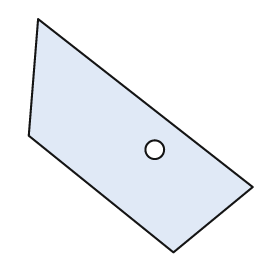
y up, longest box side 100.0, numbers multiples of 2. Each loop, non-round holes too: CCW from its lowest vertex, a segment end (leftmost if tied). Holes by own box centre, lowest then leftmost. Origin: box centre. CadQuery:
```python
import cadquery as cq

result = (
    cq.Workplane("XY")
    .moveTo(14.0, -50.0)
    .lineTo(48.0, -22.0)
    .lineTo(-44.0, 50.0)
    .lineTo(-48.0, 0.0)
    .close()
    .moveTo(6.0, -6.0)
    .circle(4.0)
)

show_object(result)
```